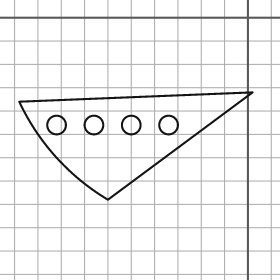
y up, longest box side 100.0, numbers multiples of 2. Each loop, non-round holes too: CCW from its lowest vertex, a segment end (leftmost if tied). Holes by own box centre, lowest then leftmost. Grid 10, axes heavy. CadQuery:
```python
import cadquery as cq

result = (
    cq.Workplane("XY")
    .moveTo(-60.0, -78.0)
    .lineTo(2.0, -32.0)
    .lineTo(-98.0, -36.0)
    .threePointArc((-82.0, -60.0), (-60.0, -78.0))
    .close()
    .moveTo(-82.0, -46.0)
    .circle(4.0)
    .moveTo(-66.0, -46.0)
    .circle(4.0)
    .moveTo(-50.0, -46.0)
    .circle(4.0)
    .moveTo(-34.0, -46.0)
    .circle(4.0)
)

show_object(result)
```